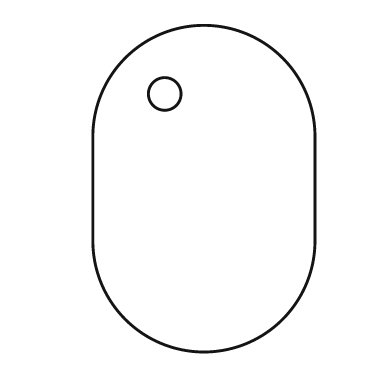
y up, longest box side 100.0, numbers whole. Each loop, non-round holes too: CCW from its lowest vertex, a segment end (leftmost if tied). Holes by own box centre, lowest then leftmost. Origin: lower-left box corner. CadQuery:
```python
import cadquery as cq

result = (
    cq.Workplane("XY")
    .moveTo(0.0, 34.0)
    .threePointArc((34.0, 0.0), (68.0, 34.0))
    .lineTo(68.0, 66.0)
    .threePointArc((34.0, 100.0), (0.0, 66.0))
    .close()
    .moveTo(22.0, 79.0)
    .circle(5.0)
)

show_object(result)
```